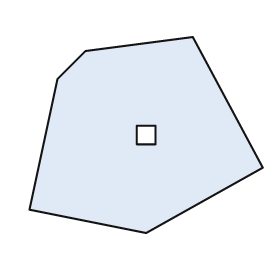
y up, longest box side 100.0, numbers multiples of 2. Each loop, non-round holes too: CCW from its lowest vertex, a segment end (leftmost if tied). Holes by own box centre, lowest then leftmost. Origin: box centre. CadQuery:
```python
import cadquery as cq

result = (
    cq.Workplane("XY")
    .moveTo(0.0, -42.0)
    .lineTo(50.0, -14.0)
    .lineTo(20.0, 42.0)
    .lineTo(-26.0, 36.0)
    .lineTo(-38.0, 24.0)
    .lineTo(-50.0, -32.0)
    .close()
    .moveTo(-4.0, -4.0)
    .lineTo(4.0, -4.0)
    .lineTo(4.0, 4.0)
    .lineTo(-4.0, 4.0)
    .close()
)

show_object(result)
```